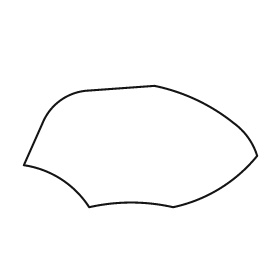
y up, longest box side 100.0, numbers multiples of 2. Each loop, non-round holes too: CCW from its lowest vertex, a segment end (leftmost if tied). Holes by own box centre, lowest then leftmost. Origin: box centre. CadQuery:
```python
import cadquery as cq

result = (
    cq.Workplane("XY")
    .moveTo(-22.0, -26.0)
    .threePointArc((-4.0, -24.0), (14.0, -26.0))
    .threePointArc((34.0, -18.0), (50.0, -4.0))
    .threePointArc((46.0, 4.0), (40.0, 10.0))
    .threePointArc((24.0, 20.0), (6.0, 26.0))
    .lineTo(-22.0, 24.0)
    .threePointArc((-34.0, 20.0), (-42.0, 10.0))
    .lineTo(-50.0, -8.0)
    .threePointArc((-34.0, -14.0), (-22.0, -26.0))
    .close()
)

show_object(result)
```